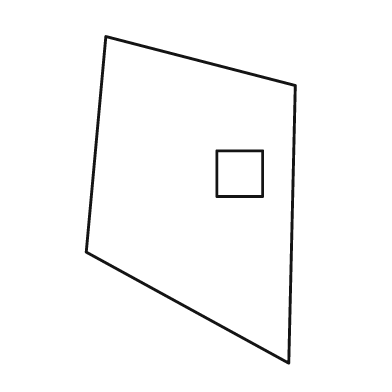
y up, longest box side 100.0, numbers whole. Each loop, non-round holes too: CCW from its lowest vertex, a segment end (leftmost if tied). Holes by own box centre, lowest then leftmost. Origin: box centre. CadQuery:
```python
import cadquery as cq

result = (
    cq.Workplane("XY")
    .moveTo(30.0, -50.0)
    .lineTo(32.0, 35.0)
    .lineTo(-26.0, 50.0)
    .lineTo(-32.0, -16.0)
    .close()
    .moveTo(8.0, 1.0)
    .lineTo(22.0, 1.0)
    .lineTo(22.0, 15.0)
    .lineTo(8.0, 15.0)
    .close()
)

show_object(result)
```